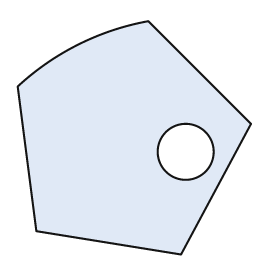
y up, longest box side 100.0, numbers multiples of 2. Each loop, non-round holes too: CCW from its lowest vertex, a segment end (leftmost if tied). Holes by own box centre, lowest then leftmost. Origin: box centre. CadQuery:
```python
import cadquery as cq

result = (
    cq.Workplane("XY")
    .moveTo(20.0, -50.0)
    .lineTo(50.0, 6.0)
    .lineTo(6.0, 50.0)
    .threePointArc((-24.0, 40.0), (-50.0, 22.0))
    .lineTo(-42.0, -40.0)
    .close()
    .moveTo(22.0, -6.0)
    .circle(12.0)
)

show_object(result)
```